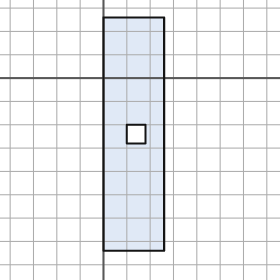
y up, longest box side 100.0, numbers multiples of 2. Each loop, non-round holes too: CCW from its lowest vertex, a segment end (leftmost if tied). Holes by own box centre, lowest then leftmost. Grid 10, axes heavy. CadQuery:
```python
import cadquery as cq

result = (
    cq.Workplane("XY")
    .moveTo(0.0, -74.0)
    .lineTo(26.0, -74.0)
    .lineTo(26.0, 26.0)
    .lineTo(0.0, 26.0)
    .close()
    .moveTo(10.0, -28.0)
    .lineTo(18.0, -28.0)
    .lineTo(18.0, -20.0)
    .lineTo(10.0, -20.0)
    .close()
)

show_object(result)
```